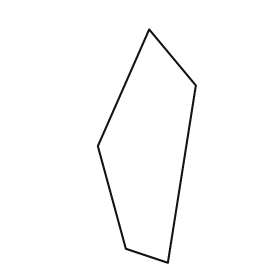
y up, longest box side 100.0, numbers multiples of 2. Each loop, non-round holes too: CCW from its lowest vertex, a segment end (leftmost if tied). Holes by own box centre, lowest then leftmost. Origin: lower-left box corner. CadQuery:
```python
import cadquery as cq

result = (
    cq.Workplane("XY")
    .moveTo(30.0, 0.0)
    .lineTo(42.0, 76.0)
    .lineTo(22.0, 100.0)
    .lineTo(0.0, 50.0)
    .lineTo(12.0, 6.0)
    .close()
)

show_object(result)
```